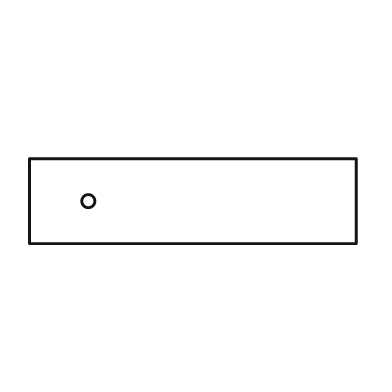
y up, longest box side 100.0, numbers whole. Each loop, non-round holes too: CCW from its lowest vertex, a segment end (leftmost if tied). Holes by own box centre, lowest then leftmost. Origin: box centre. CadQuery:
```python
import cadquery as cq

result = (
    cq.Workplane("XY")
    .moveTo(-50.0, -13.0)
    .lineTo(50.0, -13.0)
    .lineTo(50.0, 13.0)
    .lineTo(-50.0, 13.0)
    .close()
    .moveTo(-32.0, 0.0)
    .circle(2.0)
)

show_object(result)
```